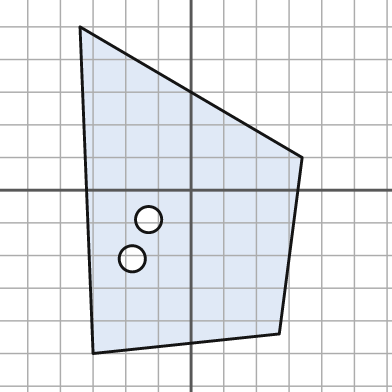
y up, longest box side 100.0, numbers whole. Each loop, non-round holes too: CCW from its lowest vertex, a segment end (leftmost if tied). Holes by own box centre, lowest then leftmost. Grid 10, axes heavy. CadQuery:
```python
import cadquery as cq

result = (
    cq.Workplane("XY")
    .moveTo(-30.0, -50.0)
    .lineTo(27.0, -44.0)
    .lineTo(34.0, 10.0)
    .lineTo(-34.0, 50.0)
    .close()
    .moveTo(-18.0, -21.0)
    .circle(4.0)
    .moveTo(-13.0, -9.0)
    .circle(4.0)
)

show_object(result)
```